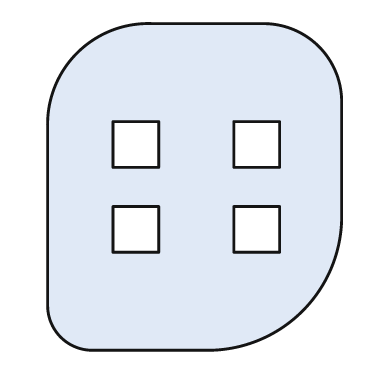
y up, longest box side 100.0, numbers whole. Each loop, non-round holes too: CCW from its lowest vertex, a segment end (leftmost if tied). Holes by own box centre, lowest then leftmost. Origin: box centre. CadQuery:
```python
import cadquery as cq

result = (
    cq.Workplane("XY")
    .moveTo(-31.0, -50.0)
    .lineTo(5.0, -50.0)
    .threePointArc((33.0, -38.0), (45.0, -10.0))
    .lineTo(45.0, 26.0)
    .threePointArc((38.0, 43.0), (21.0, 50.0))
    .lineTo(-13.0, 50.0)
    .threePointArc((-36.0, 41.0), (-45.0, 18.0))
    .lineTo(-45.0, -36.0)
    .threePointArc((-41.0, -46.0), (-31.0, -50.0))
    .close()
    .moveTo(-25.0, -20.0)
    .lineTo(-11.0, -20.0)
    .lineTo(-11.0, -6.0)
    .lineTo(-25.0, -6.0)
    .close()
    .moveTo(12.0, -20.0)
    .lineTo(26.0, -20.0)
    .lineTo(26.0, -6.0)
    .lineTo(12.0, -6.0)
    .close()
    .moveTo(-25.0, 6.0)
    .lineTo(-11.0, 6.0)
    .lineTo(-11.0, 20.0)
    .lineTo(-25.0, 20.0)
    .close()
    .moveTo(12.0, 6.0)
    .lineTo(26.0, 6.0)
    .lineTo(26.0, 20.0)
    .lineTo(12.0, 20.0)
    .close()
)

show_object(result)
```